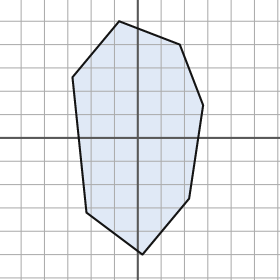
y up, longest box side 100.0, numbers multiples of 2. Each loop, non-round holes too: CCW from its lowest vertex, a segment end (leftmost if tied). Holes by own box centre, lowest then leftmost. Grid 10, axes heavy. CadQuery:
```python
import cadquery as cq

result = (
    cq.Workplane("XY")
    .moveTo(2.0, -50.0)
    .lineTo(22.0, -26.0)
    .lineTo(28.0, 14.0)
    .lineTo(18.0, 40.0)
    .lineTo(-8.0, 50.0)
    .lineTo(-28.0, 26.0)
    .lineTo(-22.0, -32.0)
    .close()
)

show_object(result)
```